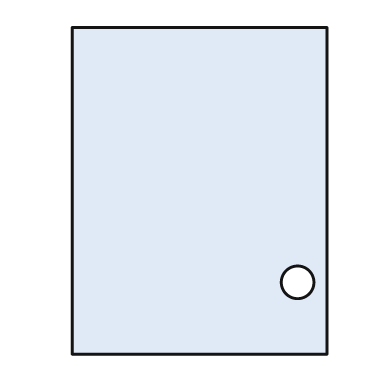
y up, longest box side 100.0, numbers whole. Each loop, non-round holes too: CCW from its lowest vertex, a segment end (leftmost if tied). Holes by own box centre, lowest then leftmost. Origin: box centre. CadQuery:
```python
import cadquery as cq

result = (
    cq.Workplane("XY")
    .moveTo(-39.0, -50.0)
    .lineTo(39.0, -50.0)
    .lineTo(39.0, 50.0)
    .lineTo(-39.0, 50.0)
    .close()
    .moveTo(30.0, -28.0)
    .circle(5.0)
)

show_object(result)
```